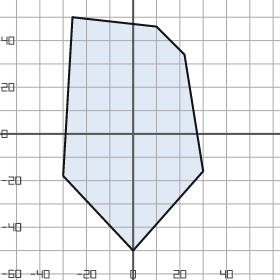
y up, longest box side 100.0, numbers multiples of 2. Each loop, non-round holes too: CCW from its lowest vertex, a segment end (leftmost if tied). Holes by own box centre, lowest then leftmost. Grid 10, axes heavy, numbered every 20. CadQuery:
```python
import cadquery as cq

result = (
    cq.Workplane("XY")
    .moveTo(0.0, -50.0)
    .lineTo(30.0, -16.0)
    .lineTo(22.0, 34.0)
    .lineTo(10.0, 46.0)
    .lineTo(-26.0, 50.0)
    .lineTo(-30.0, -18.0)
    .close()
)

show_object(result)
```